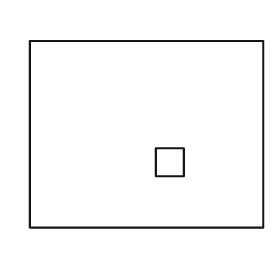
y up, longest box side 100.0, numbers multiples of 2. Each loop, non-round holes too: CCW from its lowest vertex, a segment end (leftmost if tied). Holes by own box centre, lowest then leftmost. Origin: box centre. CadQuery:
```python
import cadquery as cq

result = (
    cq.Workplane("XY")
    .moveTo(-50.0, -40.0)
    .lineTo(50.0, -40.0)
    .lineTo(50.0, 40.0)
    .lineTo(-50.0, 40.0)
    .close()
    .moveTo(4.0, -18.0)
    .lineTo(16.0, -18.0)
    .lineTo(16.0, -6.0)
    .lineTo(4.0, -6.0)
    .close()
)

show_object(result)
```